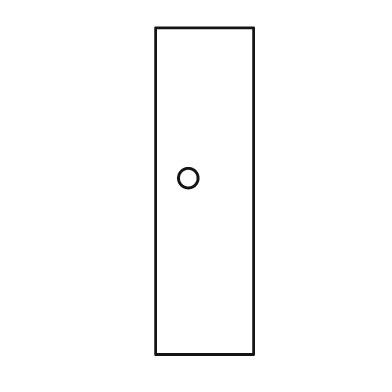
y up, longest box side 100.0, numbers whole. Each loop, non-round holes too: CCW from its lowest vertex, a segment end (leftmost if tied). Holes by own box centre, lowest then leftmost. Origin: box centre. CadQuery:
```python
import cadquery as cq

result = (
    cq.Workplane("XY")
    .moveTo(-15.0, -50.0)
    .lineTo(15.0, -50.0)
    .lineTo(15.0, 50.0)
    .lineTo(-15.0, 50.0)
    .close()
    .moveTo(-5.0, 4.0)
    .circle(3.0)
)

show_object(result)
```